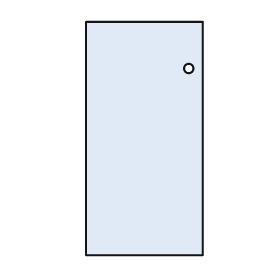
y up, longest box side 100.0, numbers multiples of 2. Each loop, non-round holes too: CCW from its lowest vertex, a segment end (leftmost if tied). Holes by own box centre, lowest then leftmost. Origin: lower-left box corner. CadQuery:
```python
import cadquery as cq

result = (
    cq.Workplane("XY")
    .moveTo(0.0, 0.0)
    .lineTo(50.0, 0.0)
    .lineTo(50.0, 100.0)
    .lineTo(0.0, 100.0)
    .close()
    .moveTo(44.0, 80.0)
    .circle(2.0)
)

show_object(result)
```